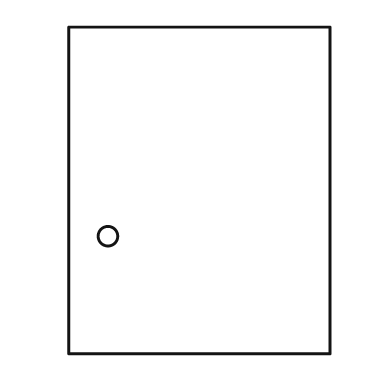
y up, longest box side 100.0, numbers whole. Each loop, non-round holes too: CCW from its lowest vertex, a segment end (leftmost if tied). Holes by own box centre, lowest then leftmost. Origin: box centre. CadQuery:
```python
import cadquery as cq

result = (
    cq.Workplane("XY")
    .moveTo(-40.0, -50.0)
    .lineTo(40.0, -50.0)
    .lineTo(40.0, 50.0)
    .lineTo(-40.0, 50.0)
    .close()
    .moveTo(-28.0, -14.0)
    .circle(3.0)
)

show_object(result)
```